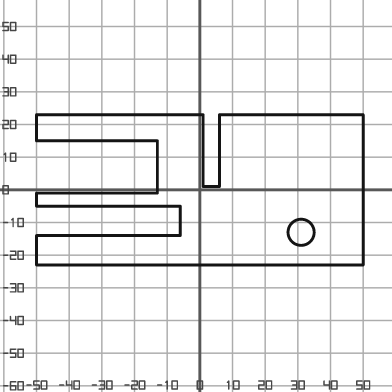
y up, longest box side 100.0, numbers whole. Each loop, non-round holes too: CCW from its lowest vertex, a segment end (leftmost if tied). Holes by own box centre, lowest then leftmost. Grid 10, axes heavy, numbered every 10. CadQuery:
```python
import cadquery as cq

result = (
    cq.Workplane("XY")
    .moveTo(-50.0, -23.0)
    .lineTo(50.0, -23.0)
    .lineTo(50.0, 23.0)
    .lineTo(6.0, 23.0)
    .lineTo(6.0, 1.0)
    .lineTo(1.0, 1.0)
    .lineTo(1.0, 23.0)
    .lineTo(-50.0, 23.0)
    .lineTo(-50.0, 15.0)
    .lineTo(-13.0, 15.0)
    .lineTo(-13.0, -1.0)
    .lineTo(-50.0, -1.0)
    .lineTo(-50.0, -5.0)
    .lineTo(-6.0, -5.0)
    .lineTo(-6.0, -14.0)
    .lineTo(-50.0, -14.0)
    .close()
    .moveTo(31.0, -13.0)
    .circle(4.0)
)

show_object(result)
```